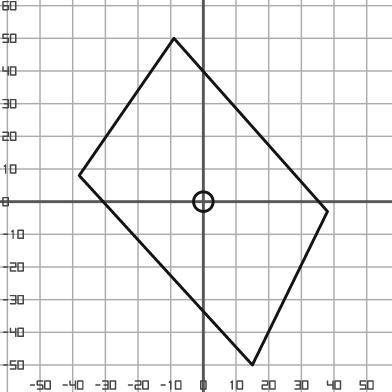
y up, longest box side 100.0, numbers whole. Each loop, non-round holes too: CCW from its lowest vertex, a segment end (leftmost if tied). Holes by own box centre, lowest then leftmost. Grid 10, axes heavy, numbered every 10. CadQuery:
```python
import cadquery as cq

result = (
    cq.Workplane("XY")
    .moveTo(15.0, -50.0)
    .lineTo(38.0, -3.0)
    .lineTo(-9.0, 50.0)
    .lineTo(-38.0, 8.0)
    .close()
    .moveTo(0.0, 0.0)
    .circle(3.0)
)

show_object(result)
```